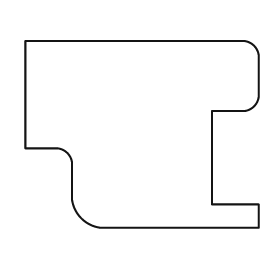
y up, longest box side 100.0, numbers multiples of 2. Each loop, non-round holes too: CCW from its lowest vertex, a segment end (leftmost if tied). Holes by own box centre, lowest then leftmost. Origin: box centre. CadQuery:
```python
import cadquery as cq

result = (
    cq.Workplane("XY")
    .moveTo(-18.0, -40.0)
    .lineTo(50.0, -40.0)
    .lineTo(50.0, -30.0)
    .lineTo(30.0, -30.0)
    .lineTo(30.0, 10.0)
    .lineTo(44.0, 10.0)
    .threePointArc((48.0, 12.0), (50.0, 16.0))
    .lineTo(50.0, 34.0)
    .threePointArc((48.0, 38.0), (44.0, 40.0))
    .lineTo(-50.0, 40.0)
    .lineTo(-50.0, -6.0)
    .lineTo(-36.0, -6.0)
    .threePointArc((-32.0, -8.0), (-30.0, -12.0))
    .lineTo(-30.0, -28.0)
    .threePointArc((-26.0, -36.0), (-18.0, -40.0))
    .close()
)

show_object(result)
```